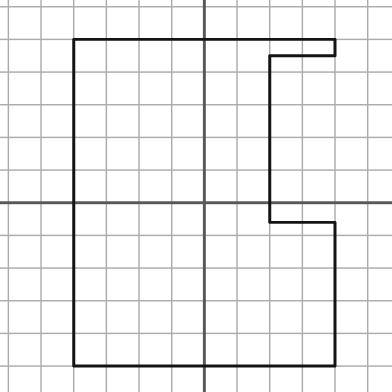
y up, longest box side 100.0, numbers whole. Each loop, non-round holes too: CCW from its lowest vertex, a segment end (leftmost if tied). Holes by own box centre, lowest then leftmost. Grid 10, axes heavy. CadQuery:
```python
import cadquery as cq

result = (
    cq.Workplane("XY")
    .moveTo(-40.0, -50.0)
    .lineTo(40.0, -50.0)
    .lineTo(40.0, -6.0)
    .lineTo(20.0, -6.0)
    .lineTo(20.0, 45.0)
    .lineTo(40.0, 45.0)
    .lineTo(40.0, 50.0)
    .lineTo(-40.0, 50.0)
    .close()
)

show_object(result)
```